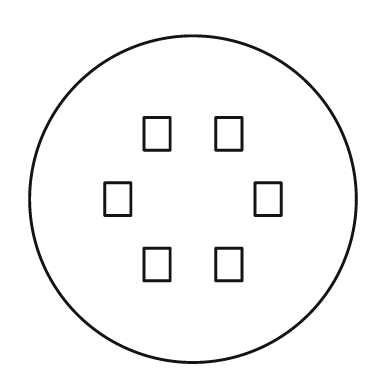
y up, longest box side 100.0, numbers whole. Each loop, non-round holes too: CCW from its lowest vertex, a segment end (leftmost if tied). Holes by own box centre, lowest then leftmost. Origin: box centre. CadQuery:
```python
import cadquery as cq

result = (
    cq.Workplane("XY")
    .moveTo(0.0, 0.0)
    .circle(50.0)
    .moveTo(-15.0, -25.0)
    .lineTo(-7.0, -25.0)
    .lineTo(-7.0, -15.0)
    .lineTo(-15.0, -15.0)
    .close()
    .moveTo(7.0, -25.0)
    .lineTo(15.0, -25.0)
    .lineTo(15.0, -15.0)
    .lineTo(7.0, -15.0)
    .close()
    .moveTo(-27.0, -5.0)
    .lineTo(-19.0, -5.0)
    .lineTo(-19.0, 5.0)
    .lineTo(-27.0, 5.0)
    .close()
    .moveTo(19.0, -5.0)
    .lineTo(27.0, -5.0)
    .lineTo(27.0, 5.0)
    .lineTo(19.0, 5.0)
    .close()
    .moveTo(-15.0, 15.0)
    .lineTo(-7.0, 15.0)
    .lineTo(-7.0, 25.0)
    .lineTo(-15.0, 25.0)
    .close()
    .moveTo(7.0, 15.0)
    .lineTo(15.0, 15.0)
    .lineTo(15.0, 25.0)
    .lineTo(7.0, 25.0)
    .close()
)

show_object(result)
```